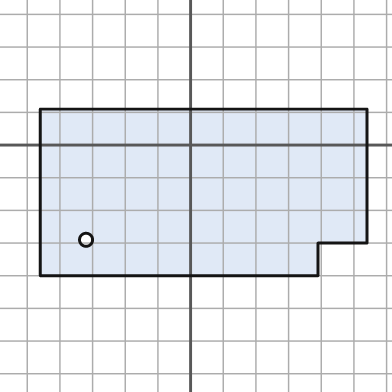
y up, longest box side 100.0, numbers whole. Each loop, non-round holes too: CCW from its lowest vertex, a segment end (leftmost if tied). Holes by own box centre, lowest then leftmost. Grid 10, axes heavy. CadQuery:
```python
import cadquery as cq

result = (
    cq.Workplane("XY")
    .moveTo(-46.0, -40.0)
    .lineTo(39.0, -40.0)
    .lineTo(39.0, -30.0)
    .lineTo(54.0, -30.0)
    .lineTo(54.0, 11.0)
    .lineTo(-46.0, 11.0)
    .close()
    .moveTo(-32.0, -29.0)
    .circle(2.0)
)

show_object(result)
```